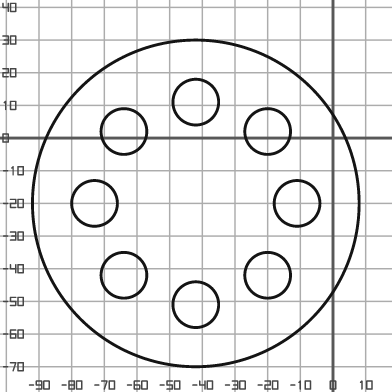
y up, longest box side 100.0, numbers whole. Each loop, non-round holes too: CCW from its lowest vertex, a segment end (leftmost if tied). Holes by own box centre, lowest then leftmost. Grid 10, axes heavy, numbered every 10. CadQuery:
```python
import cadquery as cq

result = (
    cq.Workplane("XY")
    .moveTo(-42.0, -20.0)
    .circle(50.0)
    .moveTo(-42.0, -51.0)
    .circle(7.0)
    .moveTo(-64.0, -42.0)
    .circle(7.0)
    .moveTo(-20.0, -42.0)
    .circle(7.0)
    .moveTo(-73.0, -20.0)
    .circle(7.0)
    .moveTo(-11.0, -20.0)
    .circle(7.0)
    .moveTo(-64.0, 2.0)
    .circle(7.0)
    .moveTo(-20.0, 2.0)
    .circle(7.0)
    .moveTo(-42.0, 11.0)
    .circle(7.0)
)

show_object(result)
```